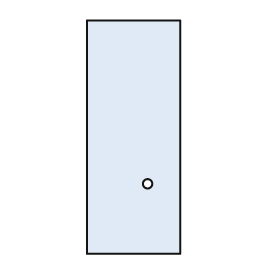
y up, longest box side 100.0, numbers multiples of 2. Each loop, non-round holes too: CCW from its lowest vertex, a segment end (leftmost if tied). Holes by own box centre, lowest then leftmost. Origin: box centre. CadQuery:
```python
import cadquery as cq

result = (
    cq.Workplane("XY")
    .moveTo(-20.0, -50.0)
    .lineTo(20.0, -50.0)
    .lineTo(20.0, 50.0)
    .lineTo(-20.0, 50.0)
    .close()
    .moveTo(6.0, -20.0)
    .circle(2.0)
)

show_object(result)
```